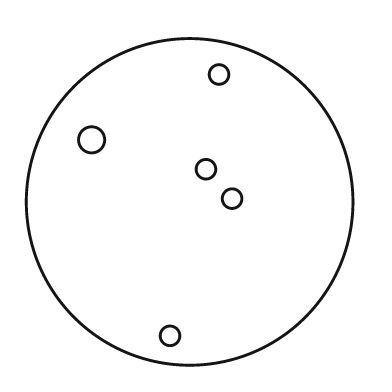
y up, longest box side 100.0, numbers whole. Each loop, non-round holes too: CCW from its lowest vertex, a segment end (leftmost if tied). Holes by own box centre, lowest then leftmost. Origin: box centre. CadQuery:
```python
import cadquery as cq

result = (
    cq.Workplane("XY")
    .moveTo(0.0, 0.0)
    .circle(50.0)
    .moveTo(-6.0, -41.0)
    .circle(3.0)
    .moveTo(13.0, 1.0)
    .circle(3.0)
    .moveTo(5.0, 10.0)
    .circle(3.0)
    .moveTo(-30.0, 19.0)
    .circle(4.0)
    .moveTo(9.0, 39.0)
    .circle(3.0)
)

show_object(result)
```